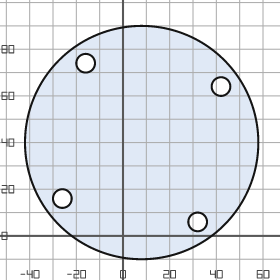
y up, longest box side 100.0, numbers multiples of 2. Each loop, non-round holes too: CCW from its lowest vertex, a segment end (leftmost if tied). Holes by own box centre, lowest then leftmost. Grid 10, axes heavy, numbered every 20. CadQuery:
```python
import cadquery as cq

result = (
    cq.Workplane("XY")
    .moveTo(8.0, 40.0)
    .circle(50.0)
    .moveTo(32.0, 6.0)
    .circle(4.0)
    .moveTo(-26.0, 16.0)
    .circle(4.0)
    .moveTo(42.0, 64.0)
    .circle(4.0)
    .moveTo(-16.0, 74.0)
    .circle(4.0)
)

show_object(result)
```